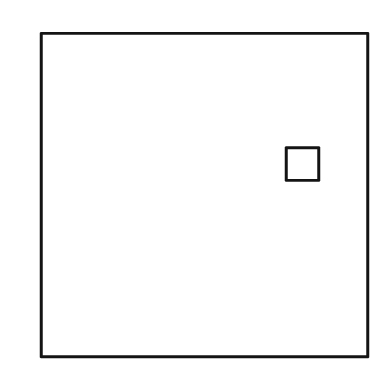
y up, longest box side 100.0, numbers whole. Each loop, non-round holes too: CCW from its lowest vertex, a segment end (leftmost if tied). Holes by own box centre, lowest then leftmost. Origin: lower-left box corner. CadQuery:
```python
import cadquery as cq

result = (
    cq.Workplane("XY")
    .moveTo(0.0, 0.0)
    .lineTo(100.0, 0.0)
    .lineTo(100.0, 99.0)
    .lineTo(0.0, 99.0)
    .close()
    .moveTo(75.0, 54.0)
    .lineTo(85.0, 54.0)
    .lineTo(85.0, 64.0)
    .lineTo(75.0, 64.0)
    .close()
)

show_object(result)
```